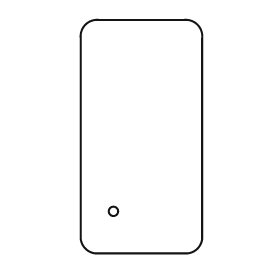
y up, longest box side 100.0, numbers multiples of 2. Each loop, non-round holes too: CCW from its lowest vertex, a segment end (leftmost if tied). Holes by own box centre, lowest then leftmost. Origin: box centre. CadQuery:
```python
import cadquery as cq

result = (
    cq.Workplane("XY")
    .moveTo(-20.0, -50.0)
    .lineTo(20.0, -50.0)
    .threePointArc((24.0, -48.0), (26.0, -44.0))
    .lineTo(26.0, 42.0)
    .threePointArc((24.0, 48.0), (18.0, 50.0))
    .lineTo(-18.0, 50.0)
    .threePointArc((-24.0, 48.0), (-26.0, 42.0))
    .lineTo(-26.0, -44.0)
    .threePointArc((-24.0, -48.0), (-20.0, -50.0))
    .close()
    .moveTo(-12.0, -32.0)
    .circle(2.0)
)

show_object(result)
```